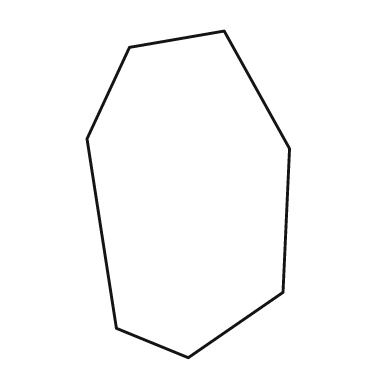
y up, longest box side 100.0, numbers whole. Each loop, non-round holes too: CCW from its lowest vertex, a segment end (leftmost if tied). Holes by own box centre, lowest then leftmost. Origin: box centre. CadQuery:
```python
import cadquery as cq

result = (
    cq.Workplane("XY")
    .moveTo(0.0, -50.0)
    .lineTo(29.0, -30.0)
    .lineTo(31.0, 14.0)
    .lineTo(11.0, 50.0)
    .lineTo(-18.0, 45.0)
    .lineTo(-31.0, 17.0)
    .lineTo(-22.0, -41.0)
    .close()
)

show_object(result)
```